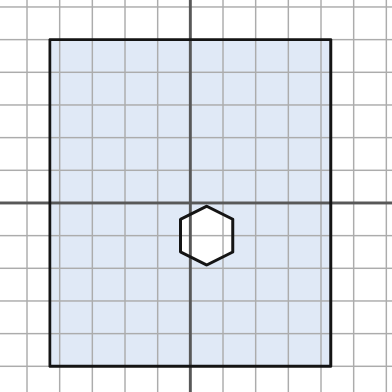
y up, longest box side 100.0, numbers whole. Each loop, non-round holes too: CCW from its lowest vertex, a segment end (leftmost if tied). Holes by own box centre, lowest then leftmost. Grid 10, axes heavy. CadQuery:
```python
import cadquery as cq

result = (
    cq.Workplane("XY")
    .moveTo(-43.0, -50.0)
    .lineTo(43.0, -50.0)
    .lineTo(43.0, 50.0)
    .lineTo(-43.0, 50.0)
    .close()
    .moveTo(5.0, -19.0)
    .lineTo(13.0, -15.0)
    .lineTo(13.0, -5.0)
    .lineTo(5.0, -1.0)
    .lineTo(-3.0, -5.0)
    .lineTo(-3.0, -15.0)
    .close()
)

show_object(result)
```